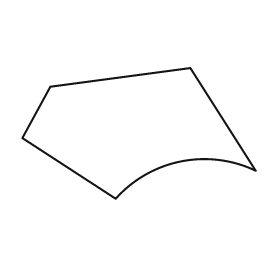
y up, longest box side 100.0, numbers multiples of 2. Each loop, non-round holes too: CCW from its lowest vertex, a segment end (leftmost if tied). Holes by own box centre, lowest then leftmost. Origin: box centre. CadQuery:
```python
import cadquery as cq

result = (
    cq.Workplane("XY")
    .moveTo(-10.0, -28.0)
    .threePointArc((18.0, -12.0), (50.0, -16.0))
    .lineTo(22.0, 28.0)
    .lineTo(-38.0, 20.0)
    .lineTo(-50.0, -2.0)
    .close()
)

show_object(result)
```